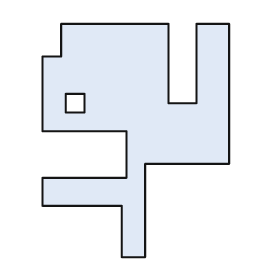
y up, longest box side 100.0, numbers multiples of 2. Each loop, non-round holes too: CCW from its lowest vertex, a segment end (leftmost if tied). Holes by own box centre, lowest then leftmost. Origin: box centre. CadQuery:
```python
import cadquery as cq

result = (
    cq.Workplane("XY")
    .moveTo(-6.0, -50.0)
    .lineTo(4.0, -50.0)
    .lineTo(4.0, -10.0)
    .lineTo(40.0, -10.0)
    .lineTo(40.0, 50.0)
    .lineTo(26.0, 50.0)
    .lineTo(26.0, 16.0)
    .lineTo(14.0, 16.0)
    .lineTo(14.0, 50.0)
    .lineTo(-32.0, 50.0)
    .lineTo(-32.0, 36.0)
    .lineTo(-40.0, 36.0)
    .lineTo(-40.0, 4.0)
    .lineTo(-4.0, 4.0)
    .lineTo(-4.0, -16.0)
    .lineTo(-40.0, -16.0)
    .lineTo(-40.0, -28.0)
    .lineTo(-6.0, -28.0)
    .close()
    .moveTo(-30.0, 12.0)
    .lineTo(-22.0, 12.0)
    .lineTo(-22.0, 20.0)
    .lineTo(-30.0, 20.0)
    .close()
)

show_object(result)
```